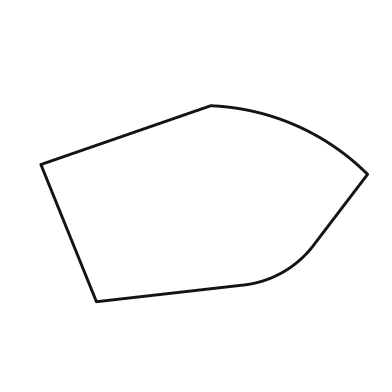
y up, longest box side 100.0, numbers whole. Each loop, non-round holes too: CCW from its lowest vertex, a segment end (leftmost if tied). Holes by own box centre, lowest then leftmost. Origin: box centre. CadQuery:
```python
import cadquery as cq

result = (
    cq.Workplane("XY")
    .moveTo(-33.0, -30.0)
    .lineTo(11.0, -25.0)
    .threePointArc((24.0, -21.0), (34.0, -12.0))
    .lineTo(50.0, 9.0)
    .threePointArc((28.0, 24.0), (2.0, 30.0))
    .lineTo(-50.0, 12.0)
    .close()
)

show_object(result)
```